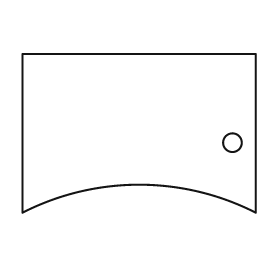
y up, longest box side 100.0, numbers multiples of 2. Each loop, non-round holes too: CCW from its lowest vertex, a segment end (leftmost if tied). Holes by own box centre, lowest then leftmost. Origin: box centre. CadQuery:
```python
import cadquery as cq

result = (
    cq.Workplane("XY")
    .moveTo(-50.0, -34.0)
    .threePointArc((0.0, -22.0), (50.0, -34.0))
    .lineTo(50.0, 34.0)
    .lineTo(-50.0, 34.0)
    .close()
    .moveTo(40.0, -4.0)
    .circle(4.0)
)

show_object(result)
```